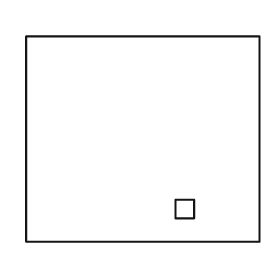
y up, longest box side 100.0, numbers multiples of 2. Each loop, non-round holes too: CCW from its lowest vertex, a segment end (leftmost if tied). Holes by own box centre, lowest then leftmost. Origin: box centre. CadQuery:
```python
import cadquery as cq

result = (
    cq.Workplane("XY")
    .moveTo(-50.0, -44.0)
    .lineTo(50.0, -44.0)
    .lineTo(50.0, 44.0)
    .lineTo(-50.0, 44.0)
    .close()
    .moveTo(14.0, -34.0)
    .lineTo(22.0, -34.0)
    .lineTo(22.0, -26.0)
    .lineTo(14.0, -26.0)
    .close()
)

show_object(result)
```